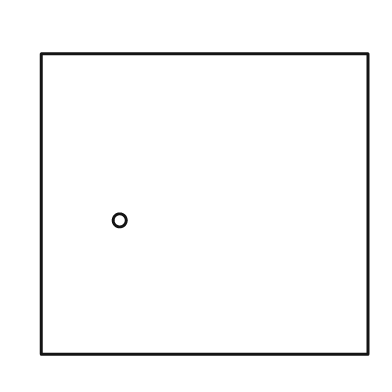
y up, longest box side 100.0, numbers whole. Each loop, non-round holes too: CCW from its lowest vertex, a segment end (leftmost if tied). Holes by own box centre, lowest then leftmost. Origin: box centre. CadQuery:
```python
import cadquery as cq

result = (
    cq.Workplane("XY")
    .moveTo(-50.0, -46.0)
    .lineTo(50.0, -46.0)
    .lineTo(50.0, 46.0)
    .lineTo(-50.0, 46.0)
    .close()
    .moveTo(-26.0, -5.0)
    .circle(2.0)
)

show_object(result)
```